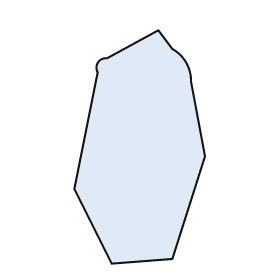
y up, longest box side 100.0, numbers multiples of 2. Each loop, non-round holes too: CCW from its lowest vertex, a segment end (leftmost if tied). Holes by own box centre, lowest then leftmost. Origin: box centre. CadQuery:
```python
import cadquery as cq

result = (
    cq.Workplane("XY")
    .moveTo(-12.0, -50.0)
    .lineTo(14.0, -48.0)
    .lineTo(28.0, -4.0)
    .lineTo(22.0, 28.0)
    .threePointArc((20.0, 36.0), (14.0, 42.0))
    .lineTo(8.0, 50.0)
    .lineTo(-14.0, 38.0)
    .threePointArc((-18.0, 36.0), (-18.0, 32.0))
    .lineTo(-28.0, -18.0)
    .close()
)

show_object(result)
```